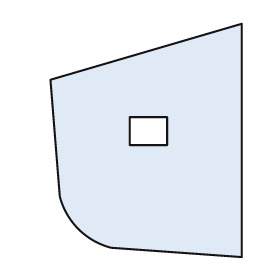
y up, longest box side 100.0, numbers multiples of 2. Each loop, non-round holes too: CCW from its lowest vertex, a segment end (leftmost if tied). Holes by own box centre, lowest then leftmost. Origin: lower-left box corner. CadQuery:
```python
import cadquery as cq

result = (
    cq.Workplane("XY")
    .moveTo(82.0, 0.0)
    .lineTo(82.0, 100.0)
    .lineTo(0.0, 76.0)
    .lineTo(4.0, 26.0)
    .threePointArc((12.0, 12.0), (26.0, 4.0))
    .close()
    .moveTo(34.0, 48.0)
    .lineTo(50.0, 48.0)
    .lineTo(50.0, 60.0)
    .lineTo(34.0, 60.0)
    .close()
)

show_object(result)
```